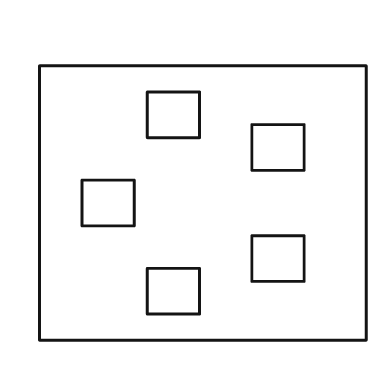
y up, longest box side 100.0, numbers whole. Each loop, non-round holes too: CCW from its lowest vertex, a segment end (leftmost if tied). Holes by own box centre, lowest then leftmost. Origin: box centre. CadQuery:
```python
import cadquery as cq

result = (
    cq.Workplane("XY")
    .moveTo(-50.0, -42.0)
    .lineTo(50.0, -42.0)
    .lineTo(50.0, 42.0)
    .lineTo(-50.0, 42.0)
    .close()
    .moveTo(-17.0, -34.0)
    .lineTo(-1.0, -34.0)
    .lineTo(-1.0, -20.0)
    .lineTo(-17.0, -20.0)
    .close()
    .moveTo(15.0, -24.0)
    .lineTo(31.0, -24.0)
    .lineTo(31.0, -10.0)
    .lineTo(15.0, -10.0)
    .close()
    .moveTo(-37.0, -7.0)
    .lineTo(-21.0, -7.0)
    .lineTo(-21.0, 7.0)
    .lineTo(-37.0, 7.0)
    .close()
    .moveTo(15.0, 10.0)
    .lineTo(31.0, 10.0)
    .lineTo(31.0, 24.0)
    .lineTo(15.0, 24.0)
    .close()
    .moveTo(-17.0, 20.0)
    .lineTo(-1.0, 20.0)
    .lineTo(-1.0, 34.0)
    .lineTo(-17.0, 34.0)
    .close()
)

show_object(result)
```